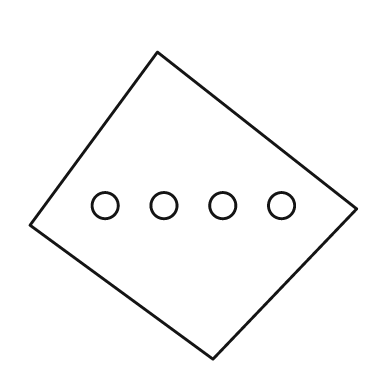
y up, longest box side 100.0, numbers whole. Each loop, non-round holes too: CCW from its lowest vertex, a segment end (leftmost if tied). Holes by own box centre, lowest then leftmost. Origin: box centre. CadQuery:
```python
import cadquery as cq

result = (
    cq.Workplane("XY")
    .moveTo(6.0, -47.0)
    .lineTo(50.0, -1.0)
    .lineTo(-11.0, 47.0)
    .lineTo(-50.0, -6.0)
    .close()
    .moveTo(-27.0, 0.0)
    .circle(4.0)
    .moveTo(-9.0, 0.0)
    .circle(4.0)
    .moveTo(9.0, 0.0)
    .circle(4.0)
    .moveTo(27.0, 0.0)
    .circle(4.0)
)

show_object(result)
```